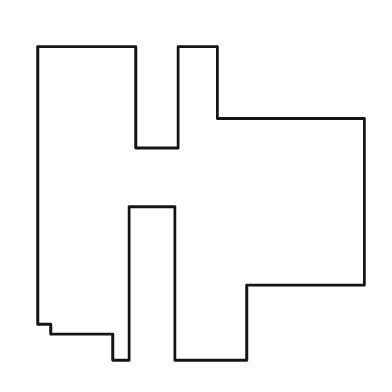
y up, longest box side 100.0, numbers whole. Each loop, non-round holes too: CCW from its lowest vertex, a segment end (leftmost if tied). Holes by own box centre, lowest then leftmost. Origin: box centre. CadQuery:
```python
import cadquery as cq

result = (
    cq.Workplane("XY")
    .moveTo(-27.0, -48.0)
    .lineTo(-22.0, -48.0)
    .lineTo(-22.0, -1.0)
    .lineTo(-8.0, -1.0)
    .lineTo(-8.0, -48.0)
    .lineTo(14.0, -48.0)
    .lineTo(14.0, -25.0)
    .lineTo(50.0, -25.0)
    .lineTo(50.0, 26.0)
    .lineTo(5.0, 26.0)
    .lineTo(5.0, 48.0)
    .lineTo(-7.0, 48.0)
    .lineTo(-7.0, 17.0)
    .lineTo(-20.0, 17.0)
    .lineTo(-20.0, 48.0)
    .lineTo(-50.0, 48.0)
    .lineTo(-50.0, -37.0)
    .lineTo(-46.0, -37.0)
    .lineTo(-46.0, -40.0)
    .lineTo(-27.0, -40.0)
    .close()
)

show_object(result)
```